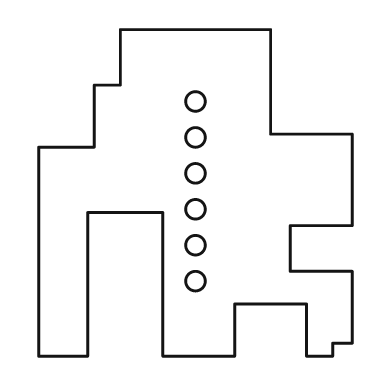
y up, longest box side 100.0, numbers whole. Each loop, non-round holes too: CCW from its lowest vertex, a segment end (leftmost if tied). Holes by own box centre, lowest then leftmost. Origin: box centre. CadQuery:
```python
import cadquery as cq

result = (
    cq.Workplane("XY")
    .moveTo(-48.0, -50.0)
    .lineTo(-33.0, -50.0)
    .lineTo(-33.0, -6.0)
    .lineTo(-10.0, -6.0)
    .lineTo(-10.0, -50.0)
    .lineTo(12.0, -50.0)
    .lineTo(12.0, -34.0)
    .lineTo(34.0, -34.0)
    .lineTo(34.0, -50.0)
    .lineTo(42.0, -50.0)
    .lineTo(42.0, -46.0)
    .lineTo(48.0, -46.0)
    .lineTo(48.0, -24.0)
    .lineTo(29.0, -24.0)
    .lineTo(29.0, -10.0)
    .lineTo(48.0, -10.0)
    .lineTo(48.0, 18.0)
    .lineTo(23.0, 18.0)
    .lineTo(23.0, 50.0)
    .lineTo(-23.0, 50.0)
    .lineTo(-23.0, 33.0)
    .lineTo(-31.0, 33.0)
    .lineTo(-31.0, 14.0)
    .lineTo(-48.0, 14.0)
    .close()
    .moveTo(0.0, -27.0)
    .circle(3.0)
    .moveTo(0.0, -16.0)
    .circle(3.0)
    .moveTo(0.0, -5.0)
    .circle(3.0)
    .moveTo(0.0, 6.0)
    .circle(3.0)
    .moveTo(0.0, 17.0)
    .circle(3.0)
    .moveTo(0.0, 28.0)
    .circle(3.0)
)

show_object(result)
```